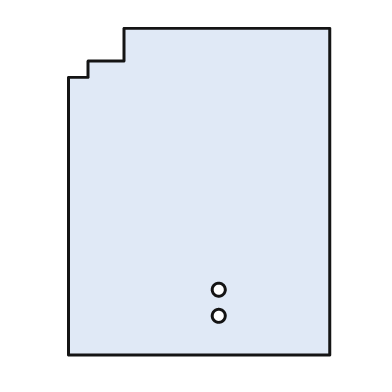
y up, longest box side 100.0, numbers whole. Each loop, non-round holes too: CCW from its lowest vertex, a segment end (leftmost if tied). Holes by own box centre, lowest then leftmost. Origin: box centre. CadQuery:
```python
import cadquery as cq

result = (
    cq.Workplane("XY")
    .moveTo(-40.0, -50.0)
    .lineTo(40.0, -50.0)
    .lineTo(40.0, 50.0)
    .lineTo(-23.0, 50.0)
    .lineTo(-23.0, 40.0)
    .lineTo(-34.0, 40.0)
    .lineTo(-34.0, 35.0)
    .lineTo(-40.0, 35.0)
    .close()
    .moveTo(6.0, -38.0)
    .circle(2.0)
    .moveTo(6.0, -30.0)
    .circle(2.0)
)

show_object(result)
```